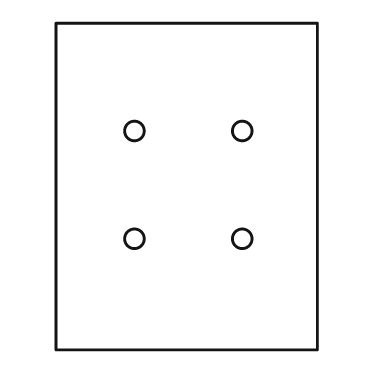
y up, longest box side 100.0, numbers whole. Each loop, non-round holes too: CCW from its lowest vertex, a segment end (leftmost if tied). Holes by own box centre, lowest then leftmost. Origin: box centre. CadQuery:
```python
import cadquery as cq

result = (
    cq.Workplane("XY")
    .moveTo(-40.0, -50.0)
    .lineTo(40.0, -50.0)
    .lineTo(40.0, 50.0)
    .lineTo(-40.0, 50.0)
    .close()
    .moveTo(-16.0, -16.0)
    .circle(3.0)
    .moveTo(17.0, -16.0)
    .circle(3.0)
    .moveTo(-16.0, 17.0)
    .circle(3.0)
    .moveTo(17.0, 17.0)
    .circle(3.0)
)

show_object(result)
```